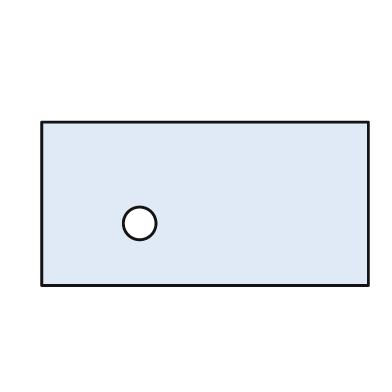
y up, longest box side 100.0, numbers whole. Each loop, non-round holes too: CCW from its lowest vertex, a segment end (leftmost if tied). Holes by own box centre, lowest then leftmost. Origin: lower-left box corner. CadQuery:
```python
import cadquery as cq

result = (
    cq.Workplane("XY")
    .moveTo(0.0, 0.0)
    .lineTo(100.0, 0.0)
    .lineTo(100.0, 50.0)
    .lineTo(0.0, 50.0)
    .close()
    .moveTo(30.0, 19.0)
    .circle(5.0)
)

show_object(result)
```